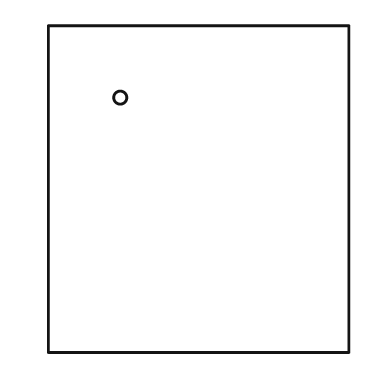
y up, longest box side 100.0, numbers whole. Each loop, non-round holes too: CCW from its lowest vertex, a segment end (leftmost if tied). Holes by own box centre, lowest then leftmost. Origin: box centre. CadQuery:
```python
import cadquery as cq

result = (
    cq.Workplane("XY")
    .moveTo(-46.0, -50.0)
    .lineTo(46.0, -50.0)
    .lineTo(46.0, 50.0)
    .lineTo(-46.0, 50.0)
    .close()
    .moveTo(-24.0, 28.0)
    .circle(2.0)
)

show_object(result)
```